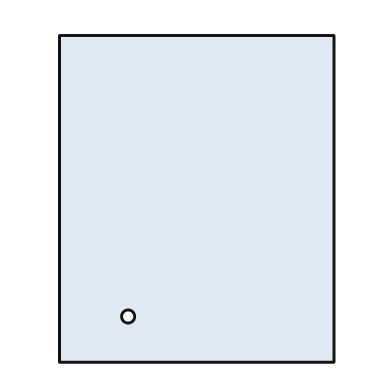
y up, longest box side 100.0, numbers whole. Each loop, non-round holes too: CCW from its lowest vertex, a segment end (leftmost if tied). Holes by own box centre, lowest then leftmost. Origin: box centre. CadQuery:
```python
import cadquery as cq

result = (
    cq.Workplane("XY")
    .moveTo(-42.0, -50.0)
    .lineTo(42.0, -50.0)
    .lineTo(42.0, 50.0)
    .lineTo(-42.0, 50.0)
    .close()
    .moveTo(-21.0, -36.0)
    .circle(2.0)
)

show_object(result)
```